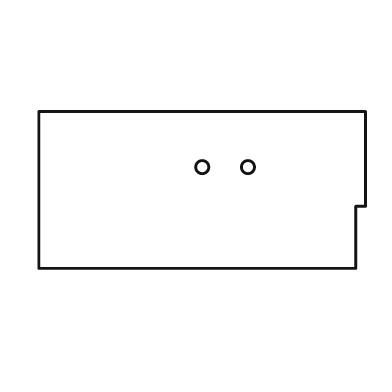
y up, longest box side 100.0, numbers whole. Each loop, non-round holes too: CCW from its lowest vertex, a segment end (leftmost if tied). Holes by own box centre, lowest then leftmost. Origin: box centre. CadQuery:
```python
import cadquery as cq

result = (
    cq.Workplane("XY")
    .moveTo(-50.0, -24.0)
    .lineTo(47.0, -24.0)
    .lineTo(47.0, -5.0)
    .lineTo(50.0, -5.0)
    .lineTo(50.0, 24.0)
    .lineTo(-50.0, 24.0)
    .close()
    .moveTo(0.0, 7.0)
    .circle(2.0)
    .moveTo(14.0, 7.0)
    .circle(2.0)
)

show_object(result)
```